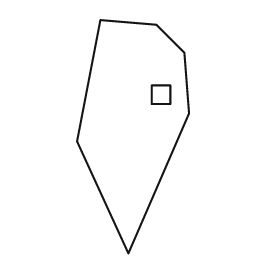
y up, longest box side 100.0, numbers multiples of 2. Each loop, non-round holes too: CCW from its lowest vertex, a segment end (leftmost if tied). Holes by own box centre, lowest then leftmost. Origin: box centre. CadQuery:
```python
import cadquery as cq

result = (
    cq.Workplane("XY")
    .moveTo(-2.0, -50.0)
    .lineTo(24.0, 10.0)
    .lineTo(22.0, 36.0)
    .lineTo(10.0, 48.0)
    .lineTo(-14.0, 50.0)
    .lineTo(-24.0, -2.0)
    .close()
    .moveTo(8.0, 14.0)
    .lineTo(16.0, 14.0)
    .lineTo(16.0, 22.0)
    .lineTo(8.0, 22.0)
    .close()
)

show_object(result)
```